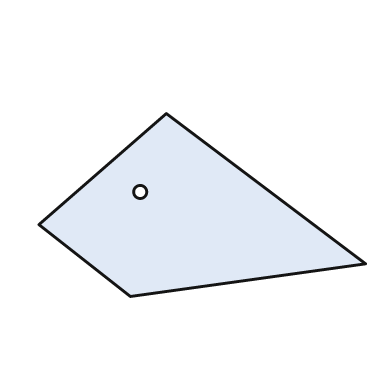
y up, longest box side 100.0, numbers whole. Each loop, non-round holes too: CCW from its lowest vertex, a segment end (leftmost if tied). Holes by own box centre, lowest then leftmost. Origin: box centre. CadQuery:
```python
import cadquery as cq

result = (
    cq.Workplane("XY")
    .moveTo(-22.0, -28.0)
    .lineTo(50.0, -18.0)
    .lineTo(-11.0, 28.0)
    .lineTo(-50.0, -6.0)
    .close()
    .moveTo(-19.0, 4.0)
    .circle(2.0)
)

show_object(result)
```